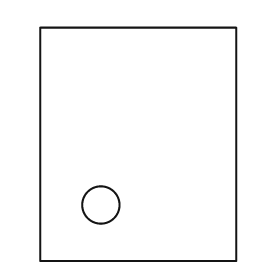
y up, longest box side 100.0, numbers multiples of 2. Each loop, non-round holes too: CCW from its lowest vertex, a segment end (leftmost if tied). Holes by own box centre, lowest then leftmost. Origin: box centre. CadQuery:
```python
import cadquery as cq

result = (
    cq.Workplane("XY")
    .moveTo(-42.0, -50.0)
    .lineTo(42.0, -50.0)
    .lineTo(42.0, 50.0)
    .lineTo(-42.0, 50.0)
    .close()
    .moveTo(-16.0, -26.0)
    .circle(8.0)
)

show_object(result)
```